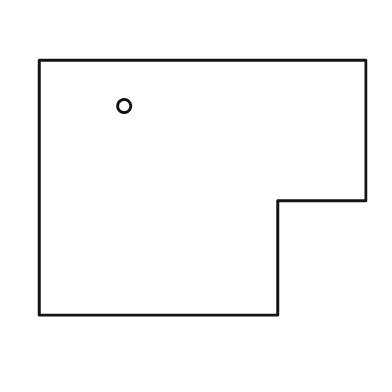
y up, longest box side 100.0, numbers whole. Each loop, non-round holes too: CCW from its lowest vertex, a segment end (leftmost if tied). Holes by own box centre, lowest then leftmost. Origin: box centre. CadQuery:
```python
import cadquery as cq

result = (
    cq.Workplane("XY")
    .moveTo(-50.0, -39.0)
    .lineTo(23.0, -39.0)
    .lineTo(23.0, -4.0)
    .lineTo(50.0, -4.0)
    .lineTo(50.0, 39.0)
    .lineTo(-50.0, 39.0)
    .close()
    .moveTo(-24.0, 25.0)
    .circle(2.0)
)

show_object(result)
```